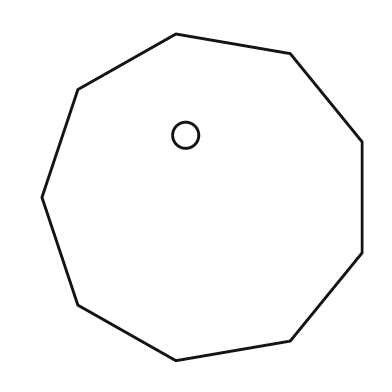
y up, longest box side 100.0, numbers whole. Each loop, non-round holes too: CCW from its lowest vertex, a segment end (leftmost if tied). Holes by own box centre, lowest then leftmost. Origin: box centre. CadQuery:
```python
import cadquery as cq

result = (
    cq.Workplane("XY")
    .moveTo(-8.0, -50.0)
    .lineTo(27.0, -44.0)
    .lineTo(49.0, -17.0)
    .lineTo(49.0, 17.0)
    .lineTo(27.0, 44.0)
    .lineTo(-8.0, 50.0)
    .lineTo(-38.0, 33.0)
    .lineTo(-49.0, 0.0)
    .lineTo(-38.0, -33.0)
    .close()
    .moveTo(-5.0, 19.0)
    .circle(4.0)
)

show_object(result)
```